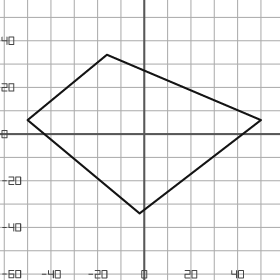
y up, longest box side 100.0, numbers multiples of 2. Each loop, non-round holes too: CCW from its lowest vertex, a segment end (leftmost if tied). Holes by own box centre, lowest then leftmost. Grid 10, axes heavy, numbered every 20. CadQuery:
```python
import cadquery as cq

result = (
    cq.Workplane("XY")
    .moveTo(-2.0, -34.0)
    .lineTo(50.0, 6.0)
    .lineTo(-16.0, 34.0)
    .lineTo(-50.0, 6.0)
    .close()
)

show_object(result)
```